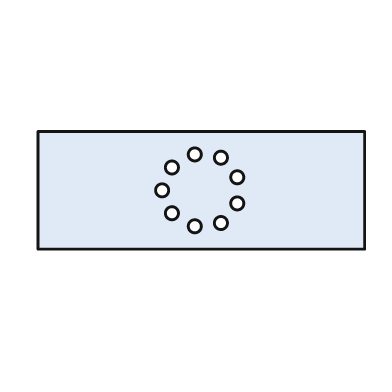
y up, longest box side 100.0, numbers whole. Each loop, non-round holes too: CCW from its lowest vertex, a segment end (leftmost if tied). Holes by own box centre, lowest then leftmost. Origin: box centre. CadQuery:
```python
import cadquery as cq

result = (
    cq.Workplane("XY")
    .moveTo(-50.0, -18.0)
    .lineTo(50.0, -18.0)
    .lineTo(50.0, 18.0)
    .lineTo(-50.0, 18.0)
    .close()
    .moveTo(-2.0, -11.0)
    .circle(2.0)
    .moveTo(6.0, -10.0)
    .circle(2.0)
    .moveTo(-9.0, -7.0)
    .circle(2.0)
    .moveTo(11.0, -4.0)
    .circle(2.0)
    .moveTo(-12.0, 0.0)
    .circle(2.0)
    .moveTo(11.0, 4.0)
    .circle(2.0)
    .moveTo(-9.0, 7.0)
    .circle(2.0)
    .moveTo(6.0, 10.0)
    .circle(2.0)
    .moveTo(-2.0, 11.0)
    .circle(2.0)
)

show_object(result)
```